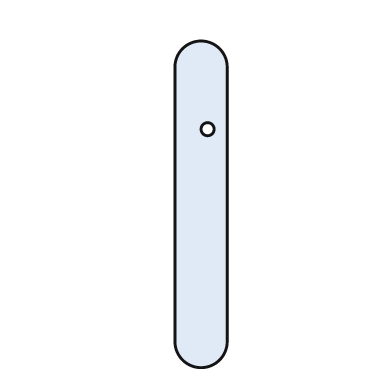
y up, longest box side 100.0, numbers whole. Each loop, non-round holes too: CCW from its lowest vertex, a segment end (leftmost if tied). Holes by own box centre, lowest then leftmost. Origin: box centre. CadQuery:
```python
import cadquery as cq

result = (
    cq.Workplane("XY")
    .moveTo(-8.0, -42.0)
    .threePointArc((0.0, -50.0), (8.0, -42.0))
    .lineTo(8.0, 42.0)
    .threePointArc((0.0, 50.0), (-8.0, 42.0))
    .close()
    .moveTo(2.0, 23.0)
    .circle(2.0)
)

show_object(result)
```